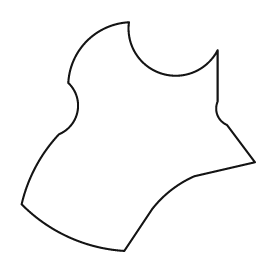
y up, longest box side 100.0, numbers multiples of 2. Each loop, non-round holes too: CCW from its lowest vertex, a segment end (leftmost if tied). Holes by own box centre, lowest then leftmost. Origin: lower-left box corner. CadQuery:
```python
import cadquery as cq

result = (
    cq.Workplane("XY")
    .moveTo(44.0, 0.0)
    .lineTo(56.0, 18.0)
    .threePointArc((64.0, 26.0), (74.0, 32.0))
    .lineTo(100.0, 38.0)
    .lineTo(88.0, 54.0)
    .threePointArc((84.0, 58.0), (84.0, 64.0))
    .lineTo(84.0, 86.0)
    .threePointArc((60.0, 76.0), (46.0, 98.0))
    .threePointArc((28.0, 90.0), (20.0, 72.0))
    .threePointArc((24.0, 60.0), (16.0, 50.0))
    .threePointArc((6.0, 36.0), (0.0, 20.0))
    .threePointArc((20.0, 6.0), (44.0, 0.0))
    .close()
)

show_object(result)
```